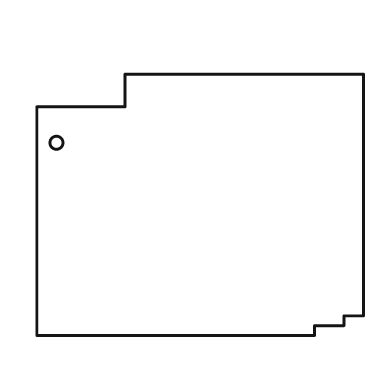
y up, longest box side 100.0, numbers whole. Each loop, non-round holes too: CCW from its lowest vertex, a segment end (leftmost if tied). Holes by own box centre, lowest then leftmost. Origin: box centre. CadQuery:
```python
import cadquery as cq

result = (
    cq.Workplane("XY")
    .moveTo(-50.0, -40.0)
    .lineTo(35.0, -40.0)
    .lineTo(35.0, -37.0)
    .lineTo(44.0, -37.0)
    .lineTo(44.0, -34.0)
    .lineTo(50.0, -34.0)
    .lineTo(50.0, 40.0)
    .lineTo(-23.0, 40.0)
    .lineTo(-23.0, 30.0)
    .lineTo(-50.0, 30.0)
    .close()
    .moveTo(-44.0, 19.0)
    .circle(2.0)
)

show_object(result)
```